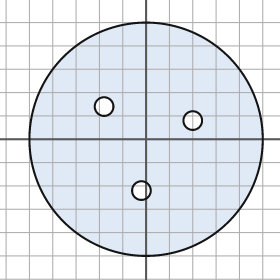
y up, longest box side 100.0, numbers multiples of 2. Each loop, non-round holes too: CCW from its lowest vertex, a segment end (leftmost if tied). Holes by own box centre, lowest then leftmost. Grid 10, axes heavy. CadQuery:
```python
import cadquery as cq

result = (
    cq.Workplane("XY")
    .moveTo(0.0, 0.0)
    .circle(50.0)
    .moveTo(-2.0, -22.0)
    .circle(4.0)
    .moveTo(20.0, 8.0)
    .circle(4.0)
    .moveTo(-18.0, 14.0)
    .circle(4.0)
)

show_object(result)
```